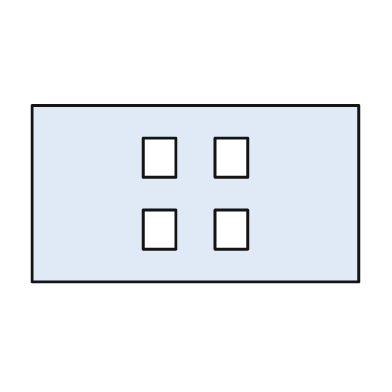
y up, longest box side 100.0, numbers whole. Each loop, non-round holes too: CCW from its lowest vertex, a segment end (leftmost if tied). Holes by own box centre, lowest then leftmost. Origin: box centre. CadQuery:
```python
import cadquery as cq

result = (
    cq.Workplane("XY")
    .moveTo(-50.0, -27.0)
    .lineTo(50.0, -27.0)
    .lineTo(50.0, 27.0)
    .lineTo(-50.0, 27.0)
    .close()
    .moveTo(-16.0, -17.0)
    .lineTo(-6.0, -17.0)
    .lineTo(-6.0, -5.0)
    .lineTo(-16.0, -5.0)
    .close()
    .moveTo(6.0, -17.0)
    .lineTo(16.0, -17.0)
    .lineTo(16.0, -5.0)
    .lineTo(6.0, -5.0)
    .close()
    .moveTo(-16.0, 5.0)
    .lineTo(-6.0, 5.0)
    .lineTo(-6.0, 17.0)
    .lineTo(-16.0, 17.0)
    .close()
    .moveTo(6.0, 5.0)
    .lineTo(16.0, 5.0)
    .lineTo(16.0, 17.0)
    .lineTo(6.0, 17.0)
    .close()
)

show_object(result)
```